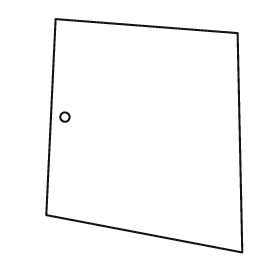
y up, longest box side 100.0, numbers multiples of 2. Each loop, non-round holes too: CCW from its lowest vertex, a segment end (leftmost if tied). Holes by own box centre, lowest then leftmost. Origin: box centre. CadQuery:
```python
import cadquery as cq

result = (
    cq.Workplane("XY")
    .moveTo(42.0, -50.0)
    .lineTo(40.0, 44.0)
    .lineTo(-38.0, 50.0)
    .lineTo(-42.0, -34.0)
    .close()
    .moveTo(-34.0, 8.0)
    .circle(2.0)
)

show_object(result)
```